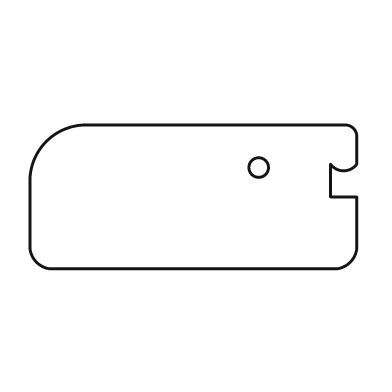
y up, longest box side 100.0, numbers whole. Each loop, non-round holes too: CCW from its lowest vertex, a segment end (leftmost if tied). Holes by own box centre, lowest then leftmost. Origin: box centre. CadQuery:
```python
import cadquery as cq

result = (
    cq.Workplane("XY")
    .moveTo(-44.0, -22.0)
    .lineTo(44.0, -22.0)
    .threePointArc((48.0, -20.0), (50.0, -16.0))
    .lineTo(50.0, 0.0)
    .lineTo(42.0, 0.0)
    .lineTo(42.0, 10.0)
    .threePointArc((46.0, 8.0), (50.0, 10.0))
    .lineTo(50.0, 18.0)
    .threePointArc((49.0, 21.0), (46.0, 22.0))
    .lineTo(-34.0, 22.0)
    .threePointArc((-45.0, 17.0), (-50.0, 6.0))
    .lineTo(-50.0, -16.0)
    .threePointArc((-48.0, -20.0), (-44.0, -22.0))
    .close()
    .moveTo(20.0, 9.0)
    .circle(3.0)
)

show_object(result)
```